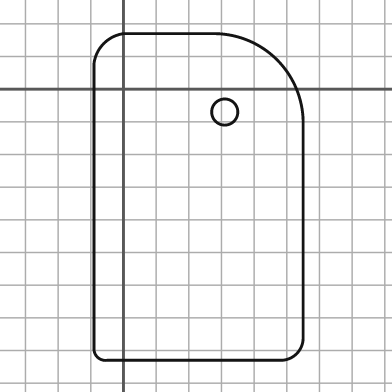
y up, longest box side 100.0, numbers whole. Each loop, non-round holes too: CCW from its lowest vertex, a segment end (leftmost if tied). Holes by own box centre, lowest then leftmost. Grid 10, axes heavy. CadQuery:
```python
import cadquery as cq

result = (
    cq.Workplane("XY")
    .moveTo(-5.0, -83.0)
    .lineTo(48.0, -83.0)
    .threePointArc((53.0, -81.0), (55.0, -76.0))
    .lineTo(55.0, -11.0)
    .threePointArc((47.0, 9.0), (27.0, 17.0))
    .lineTo(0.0, 17.0)
    .threePointArc((-6.0, 14.0), (-9.0, 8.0))
    .lineTo(-9.0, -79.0)
    .threePointArc((-8.0, -82.0), (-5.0, -83.0))
    .close()
    .moveTo(31.0, -7.0)
    .circle(4.0)
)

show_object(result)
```